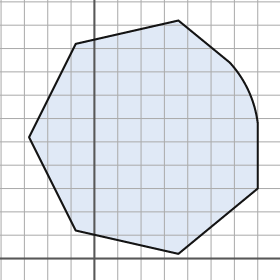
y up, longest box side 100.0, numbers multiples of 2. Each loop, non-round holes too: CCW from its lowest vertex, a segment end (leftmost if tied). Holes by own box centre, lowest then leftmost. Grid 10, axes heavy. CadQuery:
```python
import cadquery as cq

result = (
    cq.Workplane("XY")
    .moveTo(36.0, 2.0)
    .lineTo(70.0, 30.0)
    .lineTo(70.0, 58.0)
    .threePointArc((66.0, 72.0), (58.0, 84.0))
    .lineTo(36.0, 102.0)
    .lineTo(-8.0, 92.0)
    .lineTo(-28.0, 52.0)
    .lineTo(-8.0, 12.0)
    .close()
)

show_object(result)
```